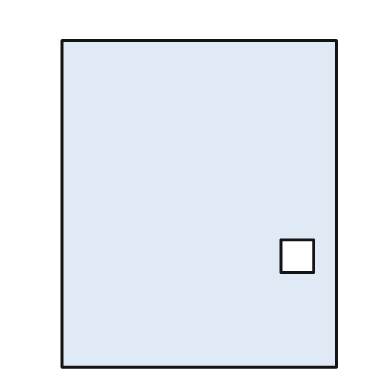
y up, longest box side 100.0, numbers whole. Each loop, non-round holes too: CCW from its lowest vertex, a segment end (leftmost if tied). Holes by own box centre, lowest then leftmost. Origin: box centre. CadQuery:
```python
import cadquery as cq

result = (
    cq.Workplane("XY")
    .moveTo(-42.0, -50.0)
    .lineTo(42.0, -50.0)
    .lineTo(42.0, 50.0)
    .lineTo(-42.0, 50.0)
    .close()
    .moveTo(25.0, -21.0)
    .lineTo(35.0, -21.0)
    .lineTo(35.0, -11.0)
    .lineTo(25.0, -11.0)
    .close()
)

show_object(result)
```